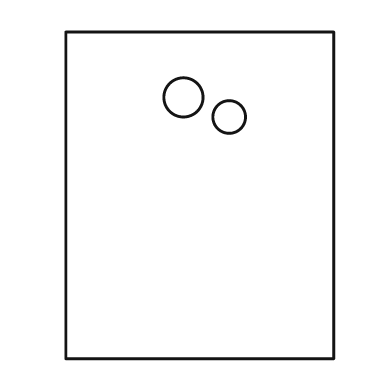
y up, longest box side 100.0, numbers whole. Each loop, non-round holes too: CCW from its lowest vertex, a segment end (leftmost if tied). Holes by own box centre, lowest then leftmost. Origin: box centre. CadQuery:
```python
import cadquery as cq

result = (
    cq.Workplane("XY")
    .moveTo(-41.0, -50.0)
    .lineTo(41.0, -50.0)
    .lineTo(41.0, 50.0)
    .lineTo(-41.0, 50.0)
    .close()
    .moveTo(9.0, 24.0)
    .circle(5.0)
    .moveTo(-5.0, 30.0)
    .circle(6.0)
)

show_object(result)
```